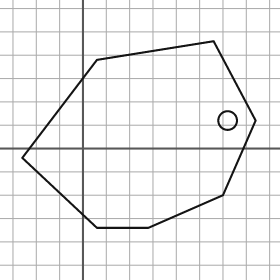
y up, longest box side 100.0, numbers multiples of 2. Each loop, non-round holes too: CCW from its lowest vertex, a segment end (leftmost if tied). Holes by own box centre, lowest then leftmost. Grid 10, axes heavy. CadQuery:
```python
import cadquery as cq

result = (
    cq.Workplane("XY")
    .moveTo(6.0, -34.0)
    .lineTo(28.0, -34.0)
    .lineTo(60.0, -20.0)
    .lineTo(74.0, 12.0)
    .lineTo(56.0, 46.0)
    .lineTo(6.0, 38.0)
    .lineTo(-26.0, -4.0)
    .close()
    .moveTo(62.0, 12.0)
    .circle(4.0)
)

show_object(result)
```